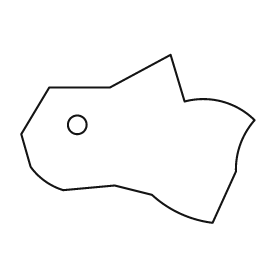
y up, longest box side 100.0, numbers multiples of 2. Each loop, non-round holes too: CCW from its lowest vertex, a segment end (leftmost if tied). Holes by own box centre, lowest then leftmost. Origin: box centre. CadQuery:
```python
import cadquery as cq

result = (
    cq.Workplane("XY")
    .moveTo(32.0, -36.0)
    .lineTo(42.0, -14.0)
    .threePointArc((44.0, -2.0), (50.0, 8.0))
    .threePointArc((36.0, 16.0), (20.0, 16.0))
    .lineTo(14.0, 36.0)
    .lineTo(-12.0, 22.0)
    .lineTo(-38.0, 22.0)
    .lineTo(-50.0, 2.0)
    .lineTo(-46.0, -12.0)
    .threePointArc((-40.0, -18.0), (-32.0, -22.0))
    .lineTo(-10.0, -20.0)
    .lineTo(6.0, -24.0)
    .threePointArc((18.0, -32.0), (32.0, -36.0))
    .close()
    .moveTo(-26.0, 6.0)
    .circle(4.0)
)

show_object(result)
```